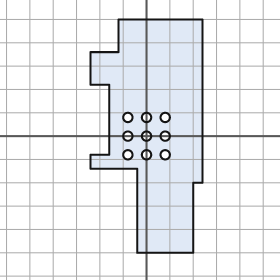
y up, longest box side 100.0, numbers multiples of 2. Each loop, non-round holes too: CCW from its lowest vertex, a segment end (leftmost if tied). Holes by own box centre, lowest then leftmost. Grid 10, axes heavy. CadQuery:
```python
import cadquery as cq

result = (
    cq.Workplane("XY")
    .moveTo(-4.0, -50.0)
    .lineTo(20.0, -50.0)
    .lineTo(20.0, -20.0)
    .lineTo(24.0, -20.0)
    .lineTo(24.0, 50.0)
    .lineTo(-12.0, 50.0)
    .lineTo(-12.0, 36.0)
    .lineTo(-24.0, 36.0)
    .lineTo(-24.0, 22.0)
    .lineTo(-16.0, 22.0)
    .lineTo(-16.0, -8.0)
    .lineTo(-24.0, -8.0)
    .lineTo(-24.0, -14.0)
    .lineTo(-4.0, -14.0)
    .close()
    .moveTo(-8.0, -8.0)
    .circle(2.0)
    .moveTo(0.0, -8.0)
    .circle(2.0)
    .moveTo(8.0, -8.0)
    .circle(2.0)
    .moveTo(-8.0, 0.0)
    .circle(2.0)
    .moveTo(0.0, 0.0)
    .circle(2.0)
    .moveTo(8.0, 0.0)
    .circle(2.0)
    .moveTo(-8.0, 8.0)
    .circle(2.0)
    .moveTo(0.0, 8.0)
    .circle(2.0)
    .moveTo(8.0, 8.0)
    .circle(2.0)
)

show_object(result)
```